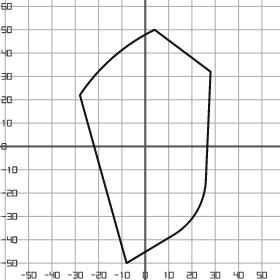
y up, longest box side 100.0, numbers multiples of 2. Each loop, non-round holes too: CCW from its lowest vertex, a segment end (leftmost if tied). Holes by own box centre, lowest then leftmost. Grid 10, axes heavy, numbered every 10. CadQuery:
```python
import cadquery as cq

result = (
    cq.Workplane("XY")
    .moveTo(-8.0, -50.0)
    .lineTo(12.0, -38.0)
    .threePointArc((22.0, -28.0), (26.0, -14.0))
    .lineTo(28.0, 32.0)
    .lineTo(4.0, 50.0)
    .threePointArc((-14.0, 38.0), (-28.0, 22.0))
    .close()
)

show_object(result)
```